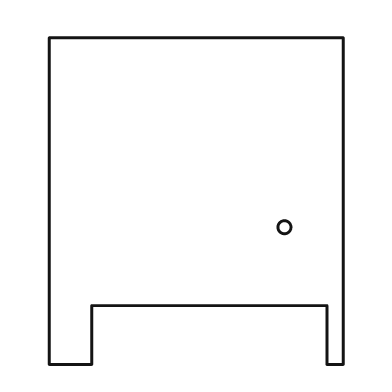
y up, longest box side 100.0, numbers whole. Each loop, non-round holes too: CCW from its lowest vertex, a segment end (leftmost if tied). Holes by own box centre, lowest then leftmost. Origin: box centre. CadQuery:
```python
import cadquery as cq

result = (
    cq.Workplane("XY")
    .moveTo(-45.0, -50.0)
    .lineTo(-32.0, -50.0)
    .lineTo(-32.0, -32.0)
    .lineTo(40.0, -32.0)
    .lineTo(40.0, -50.0)
    .lineTo(45.0, -50.0)
    .lineTo(45.0, 50.0)
    .lineTo(-45.0, 50.0)
    .close()
    .moveTo(27.0, -8.0)
    .circle(2.0)
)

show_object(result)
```